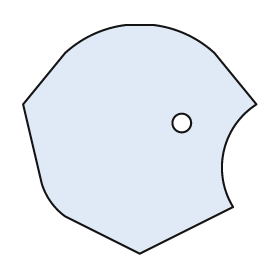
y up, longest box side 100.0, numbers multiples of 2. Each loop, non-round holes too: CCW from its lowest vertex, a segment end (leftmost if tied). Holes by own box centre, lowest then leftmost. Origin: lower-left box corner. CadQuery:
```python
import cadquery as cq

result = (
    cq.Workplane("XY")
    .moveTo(50.0, 0.0)
    .lineTo(90.0, 20.0)
    .threePointArc((86.0, 44.0), (100.0, 64.0))
    .lineTo(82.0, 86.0)
    .threePointArc((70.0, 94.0), (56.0, 98.0))
    .lineTo(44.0, 98.0)
    .threePointArc((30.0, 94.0), (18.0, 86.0))
    .lineTo(0.0, 64.0)
    .lineTo(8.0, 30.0)
    .threePointArc((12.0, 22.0), (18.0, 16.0))
    .close()
    .moveTo(68.0, 56.0)
    .circle(4.0)
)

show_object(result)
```